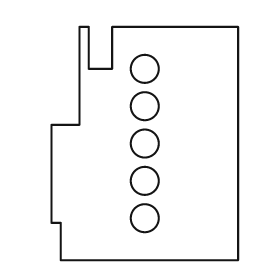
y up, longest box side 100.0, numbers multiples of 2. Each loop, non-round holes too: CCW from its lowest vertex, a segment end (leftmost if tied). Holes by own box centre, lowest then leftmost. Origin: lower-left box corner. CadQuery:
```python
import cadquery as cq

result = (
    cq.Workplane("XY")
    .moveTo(4.0, 0.0)
    .lineTo(80.0, 0.0)
    .lineTo(80.0, 100.0)
    .lineTo(26.0, 100.0)
    .lineTo(26.0, 82.0)
    .lineTo(16.0, 82.0)
    .lineTo(16.0, 100.0)
    .lineTo(12.0, 100.0)
    .lineTo(12.0, 58.0)
    .lineTo(0.0, 58.0)
    .lineTo(0.0, 16.0)
    .lineTo(4.0, 16.0)
    .close()
    .moveTo(40.0, 18.0)
    .circle(6.0)
    .moveTo(40.0, 34.0)
    .circle(6.0)
    .moveTo(40.0, 50.0)
    .circle(6.0)
    .moveTo(40.0, 66.0)
    .circle(6.0)
    .moveTo(40.0, 82.0)
    .circle(6.0)
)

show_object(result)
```